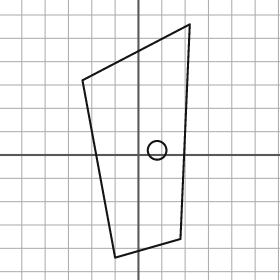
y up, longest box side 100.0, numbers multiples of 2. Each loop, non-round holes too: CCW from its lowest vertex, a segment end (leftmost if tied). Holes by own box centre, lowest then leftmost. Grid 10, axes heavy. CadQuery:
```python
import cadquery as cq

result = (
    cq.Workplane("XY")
    .moveTo(-10.0, -44.0)
    .lineTo(18.0, -36.0)
    .lineTo(22.0, 56.0)
    .lineTo(-24.0, 32.0)
    .close()
    .moveTo(8.0, 2.0)
    .circle(4.0)
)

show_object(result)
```